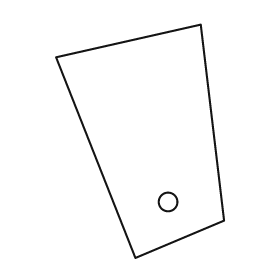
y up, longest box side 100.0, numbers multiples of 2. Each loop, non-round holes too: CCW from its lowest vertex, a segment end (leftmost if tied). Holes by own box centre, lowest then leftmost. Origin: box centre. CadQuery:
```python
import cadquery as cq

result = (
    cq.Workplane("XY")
    .moveTo(-2.0, -50.0)
    .lineTo(36.0, -34.0)
    .lineTo(26.0, 50.0)
    .lineTo(-36.0, 36.0)
    .close()
    .moveTo(12.0, -26.0)
    .circle(4.0)
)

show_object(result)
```